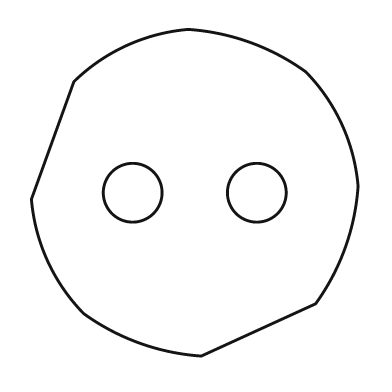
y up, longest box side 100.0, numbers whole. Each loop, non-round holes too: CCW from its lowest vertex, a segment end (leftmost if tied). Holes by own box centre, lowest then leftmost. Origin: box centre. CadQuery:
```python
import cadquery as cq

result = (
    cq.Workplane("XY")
    .moveTo(2.0, -50.0)
    .lineTo(37.0, -34.0)
    .threePointArc((46.0, -17.0), (50.0, 2.0))
    .threePointArc((45.0, 21.0), (34.0, 37.0))
    .threePointArc((17.0, 46.0), (-2.0, 50.0))
    .threePointArc((-21.0, 45.0), (-37.0, 34.0))
    .lineTo(-50.0, -2.0)
    .threePointArc((-45.0, -21.0), (-34.0, -37.0))
    .threePointArc((-17.0, -46.0), (2.0, -50.0))
    .close()
    .moveTo(-19.0, 0.0)
    .circle(9.0)
    .moveTo(19.0, 0.0)
    .circle(9.0)
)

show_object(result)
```